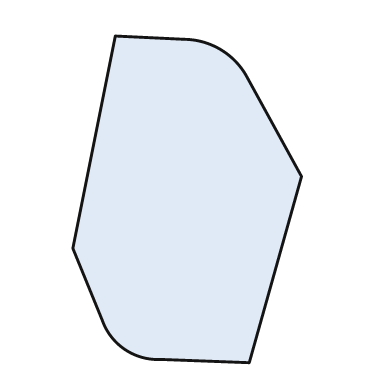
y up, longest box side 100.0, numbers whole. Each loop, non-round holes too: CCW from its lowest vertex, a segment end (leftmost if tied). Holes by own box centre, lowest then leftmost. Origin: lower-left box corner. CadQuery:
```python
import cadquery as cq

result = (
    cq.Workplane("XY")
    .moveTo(54.0, 0.0)
    .lineTo(70.0, 57.0)
    .lineTo(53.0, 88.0)
    .threePointArc((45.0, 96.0), (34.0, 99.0))
    .lineTo(13.0, 100.0)
    .lineTo(0.0, 35.0)
    .lineTo(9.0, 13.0)
    .threePointArc((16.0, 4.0), (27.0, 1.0))
    .close()
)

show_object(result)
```